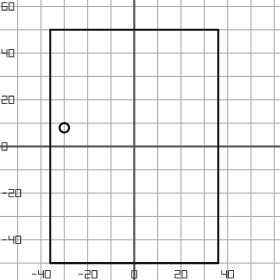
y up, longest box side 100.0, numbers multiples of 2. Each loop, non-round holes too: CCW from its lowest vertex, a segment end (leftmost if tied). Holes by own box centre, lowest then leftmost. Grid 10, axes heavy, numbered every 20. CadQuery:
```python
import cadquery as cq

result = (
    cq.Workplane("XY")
    .moveTo(-36.0, -50.0)
    .lineTo(36.0, -50.0)
    .lineTo(36.0, 50.0)
    .lineTo(-36.0, 50.0)
    .close()
    .moveTo(-30.0, 8.0)
    .circle(2.0)
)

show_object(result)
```